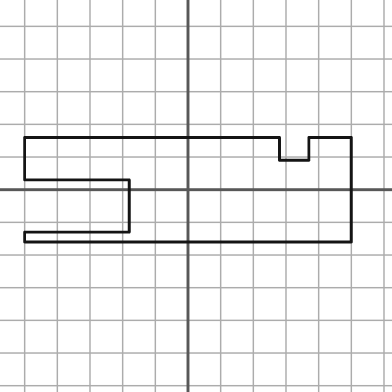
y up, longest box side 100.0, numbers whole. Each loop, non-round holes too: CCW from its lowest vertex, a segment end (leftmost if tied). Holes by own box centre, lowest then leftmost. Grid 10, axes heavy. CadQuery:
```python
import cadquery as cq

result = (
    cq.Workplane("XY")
    .moveTo(-50.0, -16.0)
    .lineTo(50.0, -16.0)
    .lineTo(50.0, 16.0)
    .lineTo(37.0, 16.0)
    .lineTo(37.0, 9.0)
    .lineTo(28.0, 9.0)
    .lineTo(28.0, 16.0)
    .lineTo(-50.0, 16.0)
    .lineTo(-50.0, 3.0)
    .lineTo(-18.0, 3.0)
    .lineTo(-18.0, -13.0)
    .lineTo(-50.0, -13.0)
    .close()
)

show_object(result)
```